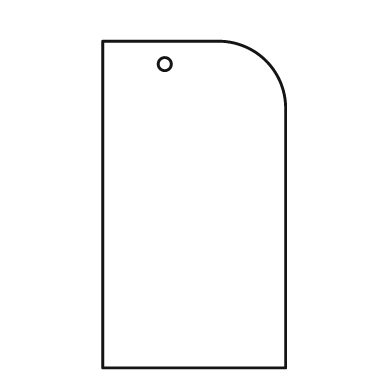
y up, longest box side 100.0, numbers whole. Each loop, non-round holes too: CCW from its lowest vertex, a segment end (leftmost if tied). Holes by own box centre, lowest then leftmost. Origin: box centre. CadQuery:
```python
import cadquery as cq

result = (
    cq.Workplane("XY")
    .moveTo(-28.0, -50.0)
    .lineTo(28.0, -50.0)
    .lineTo(28.0, 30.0)
    .threePointArc((22.0, 44.0), (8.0, 50.0))
    .lineTo(-28.0, 50.0)
    .close()
    .moveTo(-9.0, 43.0)
    .circle(2.0)
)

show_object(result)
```